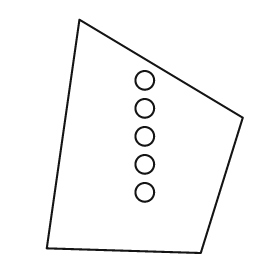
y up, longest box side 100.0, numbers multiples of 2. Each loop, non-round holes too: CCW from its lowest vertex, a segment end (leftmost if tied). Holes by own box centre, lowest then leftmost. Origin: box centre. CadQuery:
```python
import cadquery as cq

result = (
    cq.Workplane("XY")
    .moveTo(24.0, -50.0)
    .lineTo(42.0, 8.0)
    .lineTo(-28.0, 50.0)
    .lineTo(-42.0, -48.0)
    .close()
    .moveTo(0.0, -24.0)
    .circle(4.0)
    .moveTo(0.0, -12.0)
    .circle(4.0)
    .moveTo(0.0, 0.0)
    .circle(4.0)
    .moveTo(0.0, 12.0)
    .circle(4.0)
    .moveTo(0.0, 24.0)
    .circle(4.0)
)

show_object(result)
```